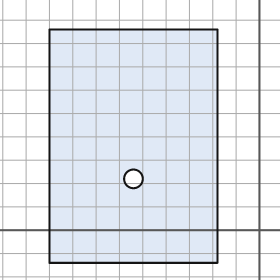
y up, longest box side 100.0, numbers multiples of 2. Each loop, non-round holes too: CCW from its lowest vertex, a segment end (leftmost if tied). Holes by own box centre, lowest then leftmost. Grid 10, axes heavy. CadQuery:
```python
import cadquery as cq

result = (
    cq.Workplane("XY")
    .moveTo(-90.0, -14.0)
    .lineTo(-18.0, -14.0)
    .lineTo(-18.0, 86.0)
    .lineTo(-90.0, 86.0)
    .close()
    .moveTo(-54.0, 22.0)
    .circle(4.0)
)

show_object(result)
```